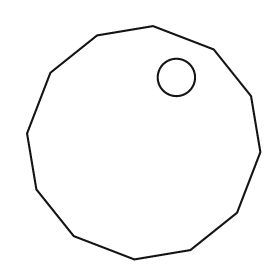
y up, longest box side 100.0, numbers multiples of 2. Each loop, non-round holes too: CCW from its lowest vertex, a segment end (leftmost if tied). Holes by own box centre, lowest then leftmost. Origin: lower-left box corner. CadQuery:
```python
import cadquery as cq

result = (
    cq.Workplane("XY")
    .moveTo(46.0, 0.0)
    .lineTo(70.0, 4.0)
    .lineTo(90.0, 20.0)
    .lineTo(100.0, 46.0)
    .lineTo(96.0, 70.0)
    .lineTo(80.0, 90.0)
    .lineTo(54.0, 100.0)
    .lineTo(30.0, 96.0)
    .lineTo(10.0, 80.0)
    .lineTo(0.0, 54.0)
    .lineTo(4.0, 30.0)
    .lineTo(20.0, 10.0)
    .close()
    .moveTo(64.0, 78.0)
    .circle(8.0)
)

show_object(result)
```